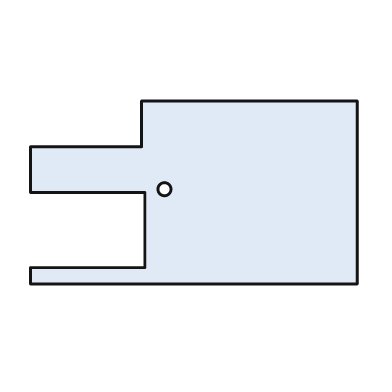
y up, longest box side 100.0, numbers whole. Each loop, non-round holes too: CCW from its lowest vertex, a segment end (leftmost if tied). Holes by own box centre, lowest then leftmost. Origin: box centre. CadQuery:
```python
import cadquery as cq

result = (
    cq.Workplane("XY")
    .moveTo(-50.0, -28.0)
    .lineTo(50.0, -28.0)
    .lineTo(50.0, 28.0)
    .lineTo(-16.0, 28.0)
    .lineTo(-16.0, 14.0)
    .lineTo(-50.0, 14.0)
    .lineTo(-50.0, 0.0)
    .lineTo(-15.0, 0.0)
    .lineTo(-15.0, -23.0)
    .lineTo(-50.0, -23.0)
    .close()
    .moveTo(-9.0, 1.0)
    .circle(2.0)
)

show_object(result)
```